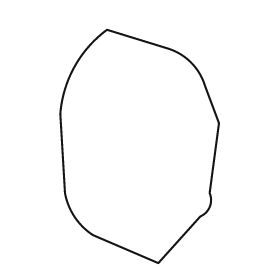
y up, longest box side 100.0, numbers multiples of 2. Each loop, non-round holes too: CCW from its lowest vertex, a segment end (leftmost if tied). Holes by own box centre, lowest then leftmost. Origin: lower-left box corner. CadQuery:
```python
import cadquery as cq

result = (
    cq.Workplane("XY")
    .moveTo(42.0, 0.0)
    .lineTo(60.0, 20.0)
    .threePointArc((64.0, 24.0), (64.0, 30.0))
    .lineTo(68.0, 60.0)
    .lineTo(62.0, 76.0)
    .threePointArc((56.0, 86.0), (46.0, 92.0))
    .lineTo(20.0, 100.0)
    .threePointArc((6.0, 84.0), (0.0, 64.0))
    .lineTo(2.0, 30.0)
    .threePointArc((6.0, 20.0), (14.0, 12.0))
    .close()
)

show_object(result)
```